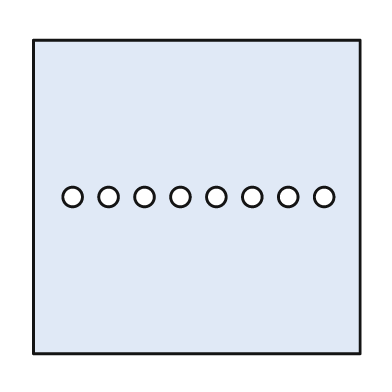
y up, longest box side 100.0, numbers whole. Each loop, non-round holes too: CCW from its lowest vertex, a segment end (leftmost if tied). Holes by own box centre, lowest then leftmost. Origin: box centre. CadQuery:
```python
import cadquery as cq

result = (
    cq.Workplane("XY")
    .moveTo(-50.0, -48.0)
    .lineTo(50.0, -48.0)
    .lineTo(50.0, 48.0)
    .lineTo(-50.0, 48.0)
    .close()
    .moveTo(-38.0, 0.0)
    .circle(3.0)
    .moveTo(-27.0, 0.0)
    .circle(3.0)
    .moveTo(-16.0, 0.0)
    .circle(3.0)
    .moveTo(-5.0, 0.0)
    .circle(3.0)
    .moveTo(6.0, 0.0)
    .circle(3.0)
    .moveTo(17.0, 0.0)
    .circle(3.0)
    .moveTo(28.0, 0.0)
    .circle(3.0)
    .moveTo(39.0, 0.0)
    .circle(3.0)
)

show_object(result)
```